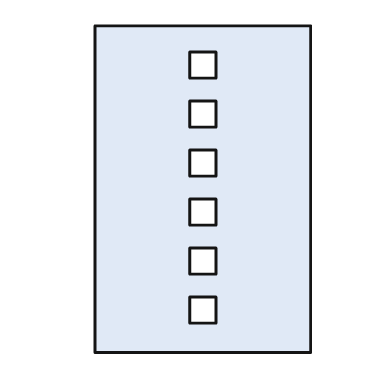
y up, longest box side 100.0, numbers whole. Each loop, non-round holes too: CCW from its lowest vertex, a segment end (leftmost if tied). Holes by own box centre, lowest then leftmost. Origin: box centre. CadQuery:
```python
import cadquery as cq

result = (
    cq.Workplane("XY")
    .moveTo(-33.0, -50.0)
    .lineTo(33.0, -50.0)
    .lineTo(33.0, 50.0)
    .lineTo(-33.0, 50.0)
    .close()
    .moveTo(-4.0, -41.0)
    .lineTo(4.0, -41.0)
    .lineTo(4.0, -33.0)
    .lineTo(-4.0, -33.0)
    .close()
    .moveTo(-4.0, -26.0)
    .lineTo(4.0, -26.0)
    .lineTo(4.0, -18.0)
    .lineTo(-4.0, -18.0)
    .close()
    .moveTo(-4.0, -11.0)
    .lineTo(4.0, -11.0)
    .lineTo(4.0, -3.0)
    .lineTo(-4.0, -3.0)
    .close()
    .moveTo(-4.0, 4.0)
    .lineTo(4.0, 4.0)
    .lineTo(4.0, 12.0)
    .lineTo(-4.0, 12.0)
    .close()
    .moveTo(-4.0, 19.0)
    .lineTo(4.0, 19.0)
    .lineTo(4.0, 27.0)
    .lineTo(-4.0, 27.0)
    .close()
    .moveTo(-4.0, 34.0)
    .lineTo(4.0, 34.0)
    .lineTo(4.0, 42.0)
    .lineTo(-4.0, 42.0)
    .close()
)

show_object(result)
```